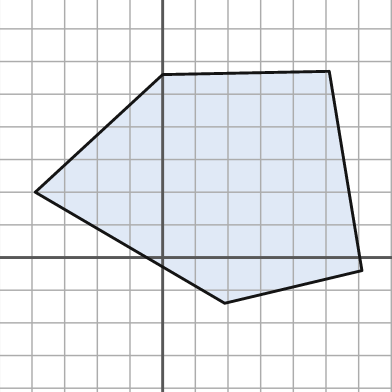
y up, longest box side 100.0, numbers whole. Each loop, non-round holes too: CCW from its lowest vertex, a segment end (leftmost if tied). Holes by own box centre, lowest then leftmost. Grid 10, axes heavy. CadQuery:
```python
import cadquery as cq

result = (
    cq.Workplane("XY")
    .moveTo(19.0, -14.0)
    .lineTo(61.0, -4.0)
    .lineTo(51.0, 57.0)
    .lineTo(0.0, 56.0)
    .lineTo(-39.0, 20.0)
    .close()
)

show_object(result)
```